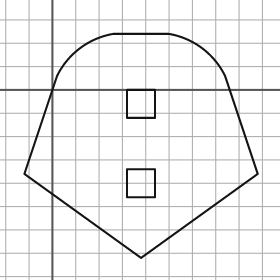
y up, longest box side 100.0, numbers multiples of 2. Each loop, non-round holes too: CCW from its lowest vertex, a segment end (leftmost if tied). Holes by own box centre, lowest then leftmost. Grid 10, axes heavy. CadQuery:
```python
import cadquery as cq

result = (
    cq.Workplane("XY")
    .moveTo(38.0, -72.0)
    .lineTo(88.0, -36.0)
    .lineTo(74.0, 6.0)
    .threePointArc((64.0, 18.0), (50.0, 24.0))
    .lineTo(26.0, 24.0)
    .threePointArc((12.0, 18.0), (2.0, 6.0))
    .lineTo(-12.0, -36.0)
    .close()
    .moveTo(32.0, -46.0)
    .lineTo(44.0, -46.0)
    .lineTo(44.0, -34.0)
    .lineTo(32.0, -34.0)
    .close()
    .moveTo(32.0, -12.0)
    .lineTo(44.0, -12.0)
    .lineTo(44.0, 0.0)
    .lineTo(32.0, 0.0)
    .close()
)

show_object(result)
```